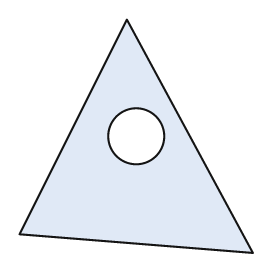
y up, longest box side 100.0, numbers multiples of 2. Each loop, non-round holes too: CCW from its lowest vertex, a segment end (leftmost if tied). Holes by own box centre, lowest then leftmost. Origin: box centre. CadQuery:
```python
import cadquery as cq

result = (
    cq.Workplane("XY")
    .moveTo(50.0, -50.0)
    .lineTo(-4.0, 50.0)
    .lineTo(-50.0, -42.0)
    .close()
    .moveTo(0.0, 0.0)
    .circle(12.0)
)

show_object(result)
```